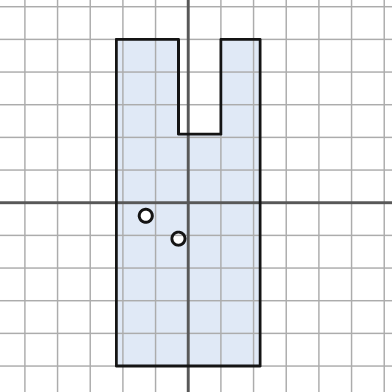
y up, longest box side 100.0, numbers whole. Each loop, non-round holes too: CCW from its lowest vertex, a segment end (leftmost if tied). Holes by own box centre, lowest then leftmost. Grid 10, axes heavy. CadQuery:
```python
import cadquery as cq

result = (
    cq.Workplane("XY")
    .moveTo(-22.0, -50.0)
    .lineTo(22.0, -50.0)
    .lineTo(22.0, 50.0)
    .lineTo(10.0, 50.0)
    .lineTo(10.0, 21.0)
    .lineTo(-3.0, 21.0)
    .lineTo(-3.0, 50.0)
    .lineTo(-22.0, 50.0)
    .close()
    .moveTo(-3.0, -11.0)
    .circle(2.0)
    .moveTo(-13.0, -4.0)
    .circle(2.0)
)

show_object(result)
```